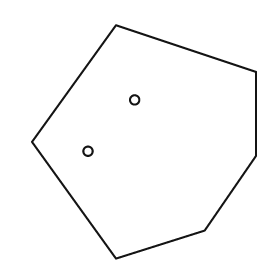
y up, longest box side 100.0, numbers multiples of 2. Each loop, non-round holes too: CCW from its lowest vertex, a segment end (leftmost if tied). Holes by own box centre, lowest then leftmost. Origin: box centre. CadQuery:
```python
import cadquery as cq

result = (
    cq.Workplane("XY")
    .moveTo(-12.0, -50.0)
    .lineTo(26.0, -38.0)
    .lineTo(48.0, -6.0)
    .lineTo(48.0, 30.0)
    .lineTo(-12.0, 50.0)
    .lineTo(-48.0, 0.0)
    .close()
    .moveTo(-24.0, -4.0)
    .circle(2.0)
    .moveTo(-4.0, 18.0)
    .circle(2.0)
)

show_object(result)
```